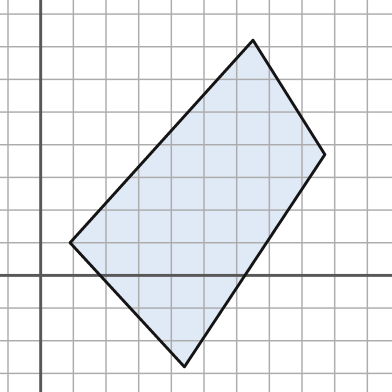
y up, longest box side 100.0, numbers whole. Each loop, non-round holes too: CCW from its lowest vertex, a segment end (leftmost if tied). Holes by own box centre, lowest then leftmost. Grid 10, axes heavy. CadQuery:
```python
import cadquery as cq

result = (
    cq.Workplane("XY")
    .moveTo(44.0, -28.0)
    .lineTo(87.0, 37.0)
    .lineTo(65.0, 72.0)
    .lineTo(9.0, 10.0)
    .close()
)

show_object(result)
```